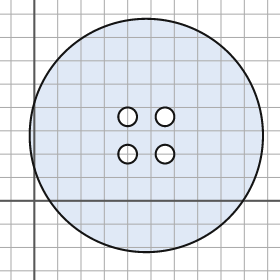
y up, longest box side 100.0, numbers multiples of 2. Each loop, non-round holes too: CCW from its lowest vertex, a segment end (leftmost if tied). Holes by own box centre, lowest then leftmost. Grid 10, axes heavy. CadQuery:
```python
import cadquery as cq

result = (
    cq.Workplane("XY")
    .moveTo(48.0, 28.0)
    .circle(50.0)
    .moveTo(40.0, 20.0)
    .circle(4.0)
    .moveTo(56.0, 20.0)
    .circle(4.0)
    .moveTo(40.0, 36.0)
    .circle(4.0)
    .moveTo(56.0, 36.0)
    .circle(4.0)
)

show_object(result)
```